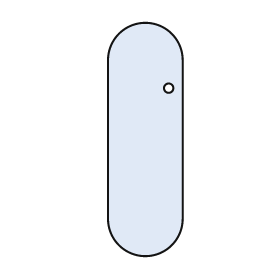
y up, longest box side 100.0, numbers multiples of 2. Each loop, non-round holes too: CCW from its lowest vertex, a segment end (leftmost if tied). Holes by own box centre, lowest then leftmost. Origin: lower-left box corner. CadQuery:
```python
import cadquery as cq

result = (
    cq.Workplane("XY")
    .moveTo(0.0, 16.0)
    .threePointArc((16.0, 0.0), (32.0, 16.0))
    .lineTo(32.0, 84.0)
    .threePointArc((16.0, 100.0), (0.0, 84.0))
    .close()
    .moveTo(26.0, 72.0)
    .circle(2.0)
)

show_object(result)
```